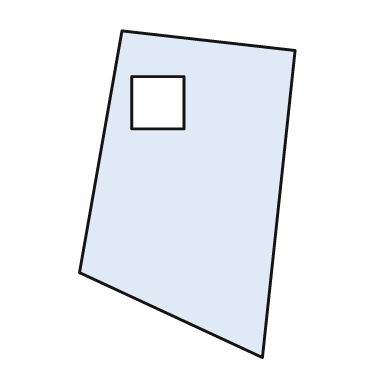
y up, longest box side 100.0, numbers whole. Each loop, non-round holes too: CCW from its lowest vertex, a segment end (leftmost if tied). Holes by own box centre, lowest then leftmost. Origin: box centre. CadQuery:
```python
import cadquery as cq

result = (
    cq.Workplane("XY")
    .moveTo(23.0, -50.0)
    .lineTo(33.0, 44.0)
    .lineTo(-20.0, 50.0)
    .lineTo(-33.0, -24.0)
    .close()
    .moveTo(-17.0, 20.0)
    .lineTo(-1.0, 20.0)
    .lineTo(-1.0, 36.0)
    .lineTo(-17.0, 36.0)
    .close()
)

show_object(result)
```